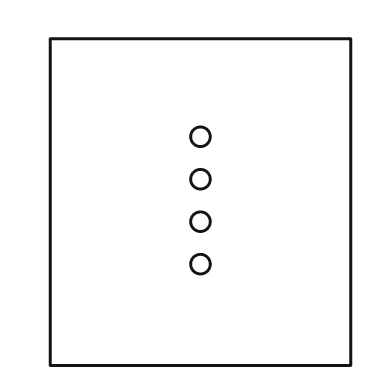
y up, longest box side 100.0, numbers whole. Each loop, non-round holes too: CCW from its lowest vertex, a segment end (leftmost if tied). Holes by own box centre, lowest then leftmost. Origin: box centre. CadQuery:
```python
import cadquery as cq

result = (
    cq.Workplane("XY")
    .moveTo(-46.0, -50.0)
    .lineTo(46.0, -50.0)
    .lineTo(46.0, 50.0)
    .lineTo(-46.0, 50.0)
    .close()
    .moveTo(0.0, -19.0)
    .circle(3.0)
    .moveTo(0.0, -6.0)
    .circle(3.0)
    .moveTo(0.0, 7.0)
    .circle(3.0)
    .moveTo(0.0, 20.0)
    .circle(3.0)
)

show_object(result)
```